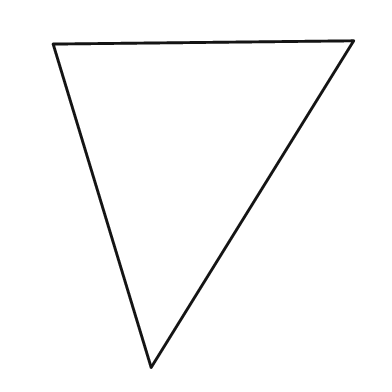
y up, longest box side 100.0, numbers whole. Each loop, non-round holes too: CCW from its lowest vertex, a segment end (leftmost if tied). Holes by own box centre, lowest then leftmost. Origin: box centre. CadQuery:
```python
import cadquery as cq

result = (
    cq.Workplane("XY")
    .moveTo(-16.0, -50.0)
    .lineTo(46.0, 50.0)
    .lineTo(-46.0, 49.0)
    .close()
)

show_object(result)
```